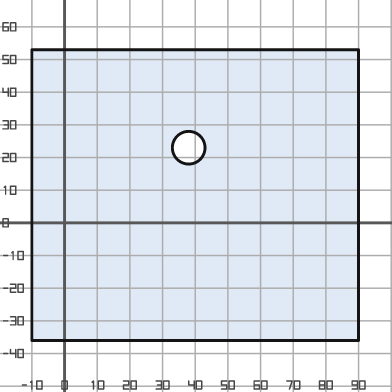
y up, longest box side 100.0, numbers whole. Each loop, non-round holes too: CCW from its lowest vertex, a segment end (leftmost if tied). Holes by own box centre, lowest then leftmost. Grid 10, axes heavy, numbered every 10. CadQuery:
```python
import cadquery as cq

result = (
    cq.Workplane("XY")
    .moveTo(-10.0, -36.0)
    .lineTo(90.0, -36.0)
    .lineTo(90.0, 53.0)
    .lineTo(-10.0, 53.0)
    .close()
    .moveTo(38.0, 23.0)
    .circle(5.0)
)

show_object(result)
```